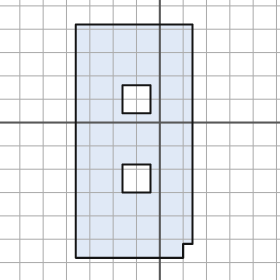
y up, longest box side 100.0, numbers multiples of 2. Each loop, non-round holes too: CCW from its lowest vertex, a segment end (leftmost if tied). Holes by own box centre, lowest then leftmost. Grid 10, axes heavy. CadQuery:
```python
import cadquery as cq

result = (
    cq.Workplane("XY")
    .moveTo(-36.0, -58.0)
    .lineTo(10.0, -58.0)
    .lineTo(10.0, -52.0)
    .lineTo(14.0, -52.0)
    .lineTo(14.0, 42.0)
    .lineTo(-36.0, 42.0)
    .close()
    .moveTo(-16.0, -30.0)
    .lineTo(-4.0, -30.0)
    .lineTo(-4.0, -18.0)
    .lineTo(-16.0, -18.0)
    .close()
    .moveTo(-16.0, 4.0)
    .lineTo(-4.0, 4.0)
    .lineTo(-4.0, 16.0)
    .lineTo(-16.0, 16.0)
    .close()
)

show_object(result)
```